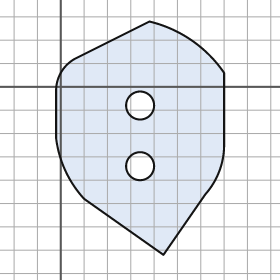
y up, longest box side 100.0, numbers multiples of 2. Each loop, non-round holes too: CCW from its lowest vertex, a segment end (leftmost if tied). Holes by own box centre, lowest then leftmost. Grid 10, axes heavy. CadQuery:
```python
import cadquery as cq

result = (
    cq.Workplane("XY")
    .moveTo(44.0, -72.0)
    .lineTo(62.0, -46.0)
    .threePointArc((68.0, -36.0), (70.0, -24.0))
    .lineTo(70.0, 6.0)
    .threePointArc((56.0, 20.0), (38.0, 28.0))
    .lineTo(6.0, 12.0)
    .threePointArc((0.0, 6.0), (-2.0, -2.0))
    .lineTo(-2.0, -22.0)
    .threePointArc((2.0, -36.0), (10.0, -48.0))
    .close()
    .moveTo(34.0, -34.0)
    .circle(6.0)
    .moveTo(34.0, -8.0)
    .circle(6.0)
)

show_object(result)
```